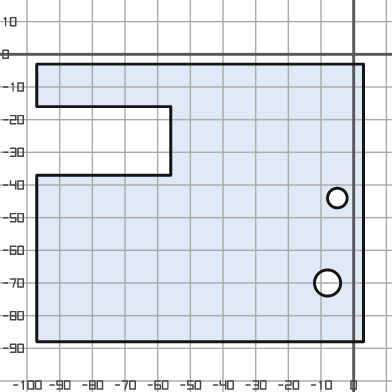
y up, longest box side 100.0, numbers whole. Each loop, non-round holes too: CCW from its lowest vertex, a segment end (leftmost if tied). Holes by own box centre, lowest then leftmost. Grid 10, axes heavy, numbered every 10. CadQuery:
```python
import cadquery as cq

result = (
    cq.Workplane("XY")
    .moveTo(-97.0, -88.0)
    .lineTo(3.0, -88.0)
    .lineTo(3.0, -3.0)
    .lineTo(-97.0, -3.0)
    .lineTo(-97.0, -16.0)
    .lineTo(-56.0, -16.0)
    .lineTo(-56.0, -37.0)
    .lineTo(-97.0, -37.0)
    .close()
    .moveTo(-8.0, -70.0)
    .circle(4.0)
    .moveTo(-5.0, -44.0)
    .circle(3.0)
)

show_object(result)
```